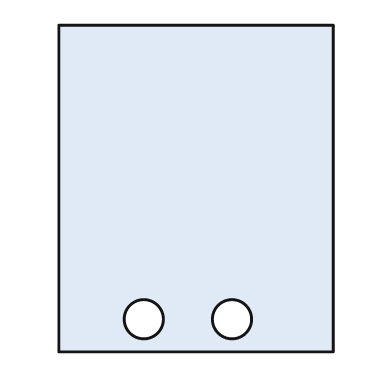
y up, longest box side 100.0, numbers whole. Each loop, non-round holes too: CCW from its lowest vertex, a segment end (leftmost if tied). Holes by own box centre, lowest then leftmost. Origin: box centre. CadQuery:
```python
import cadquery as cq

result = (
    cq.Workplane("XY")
    .moveTo(-42.0, -50.0)
    .lineTo(42.0, -50.0)
    .lineTo(42.0, 50.0)
    .lineTo(-42.0, 50.0)
    .close()
    .moveTo(-16.0, -40.0)
    .circle(6.0)
    .moveTo(11.0, -40.0)
    .circle(6.0)
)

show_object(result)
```